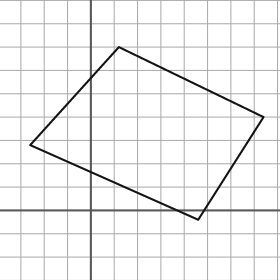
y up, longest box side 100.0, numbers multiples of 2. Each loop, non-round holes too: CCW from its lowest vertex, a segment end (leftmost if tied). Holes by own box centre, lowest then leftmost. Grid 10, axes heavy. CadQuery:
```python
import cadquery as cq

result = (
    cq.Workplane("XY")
    .moveTo(46.0, -4.0)
    .lineTo(74.0, 40.0)
    .lineTo(12.0, 70.0)
    .lineTo(-26.0, 28.0)
    .close()
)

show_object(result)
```